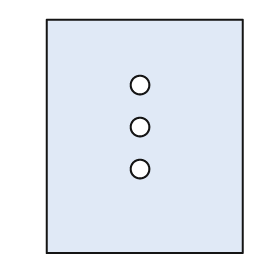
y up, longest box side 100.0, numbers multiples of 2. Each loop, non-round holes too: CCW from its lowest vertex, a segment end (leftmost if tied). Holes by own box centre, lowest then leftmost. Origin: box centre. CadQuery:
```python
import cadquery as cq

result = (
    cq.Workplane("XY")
    .moveTo(-42.0, -50.0)
    .lineTo(42.0, -50.0)
    .lineTo(42.0, 50.0)
    .lineTo(-42.0, 50.0)
    .close()
    .moveTo(-2.0, -14.0)
    .circle(4.0)
    .moveTo(-2.0, 4.0)
    .circle(4.0)
    .moveTo(-2.0, 22.0)
    .circle(4.0)
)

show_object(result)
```